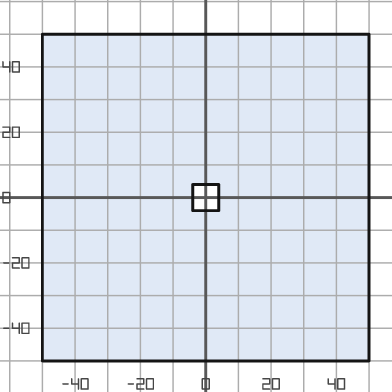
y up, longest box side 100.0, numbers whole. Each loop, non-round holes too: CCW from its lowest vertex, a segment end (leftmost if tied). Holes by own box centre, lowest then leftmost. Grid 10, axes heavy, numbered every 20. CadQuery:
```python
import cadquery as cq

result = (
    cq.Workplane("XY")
    .moveTo(-50.0, -50.0)
    .lineTo(50.0, -50.0)
    .lineTo(50.0, 50.0)
    .lineTo(-50.0, 50.0)
    .close()
    .moveTo(-4.0, -4.0)
    .lineTo(4.0, -4.0)
    .lineTo(4.0, 4.0)
    .lineTo(-4.0, 4.0)
    .close()
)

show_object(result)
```